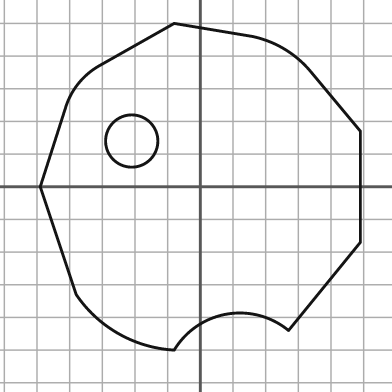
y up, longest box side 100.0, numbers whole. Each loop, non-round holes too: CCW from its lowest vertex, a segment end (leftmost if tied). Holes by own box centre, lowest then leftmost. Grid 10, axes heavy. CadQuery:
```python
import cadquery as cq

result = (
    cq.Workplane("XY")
    .moveTo(-8.0, -50.0)
    .threePointArc((8.0, -39.0), (27.0, -44.0))
    .lineTo(49.0, -17.0)
    .lineTo(49.0, 17.0)
    .lineTo(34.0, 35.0)
    .threePointArc((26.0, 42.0), (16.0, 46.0))
    .lineTo(-8.0, 50.0)
    .lineTo(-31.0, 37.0)
    .threePointArc((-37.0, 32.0), (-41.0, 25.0))
    .lineTo(-49.0, 0.0)
    .lineTo(-38.0, -33.0)
    .threePointArc((-25.0, -45.0), (-8.0, -50.0))
    .close()
    .moveTo(-21.0, 14.0)
    .circle(8.0)
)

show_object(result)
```